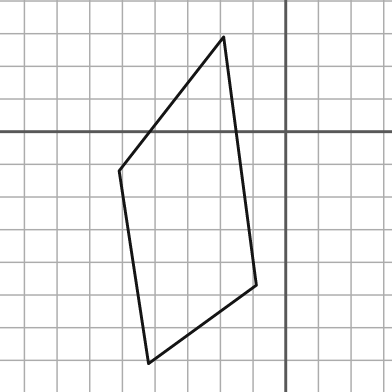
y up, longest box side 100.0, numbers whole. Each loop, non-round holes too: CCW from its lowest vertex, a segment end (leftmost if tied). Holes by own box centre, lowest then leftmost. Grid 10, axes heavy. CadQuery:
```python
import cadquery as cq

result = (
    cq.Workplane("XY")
    .moveTo(-42.0, -71.0)
    .lineTo(-9.0, -47.0)
    .lineTo(-19.0, 29.0)
    .lineTo(-51.0, -12.0)
    .close()
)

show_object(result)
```